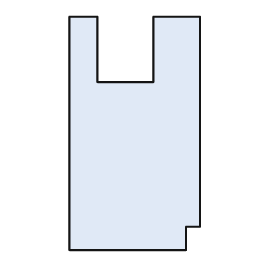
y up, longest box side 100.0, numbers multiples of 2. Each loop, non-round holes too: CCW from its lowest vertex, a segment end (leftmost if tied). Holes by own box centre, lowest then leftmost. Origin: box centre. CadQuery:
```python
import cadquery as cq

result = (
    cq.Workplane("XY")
    .moveTo(-28.0, -50.0)
    .lineTo(22.0, -50.0)
    .lineTo(22.0, -40.0)
    .lineTo(28.0, -40.0)
    .lineTo(28.0, 50.0)
    .lineTo(8.0, 50.0)
    .lineTo(8.0, 22.0)
    .lineTo(-16.0, 22.0)
    .lineTo(-16.0, 50.0)
    .lineTo(-28.0, 50.0)
    .close()
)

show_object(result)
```